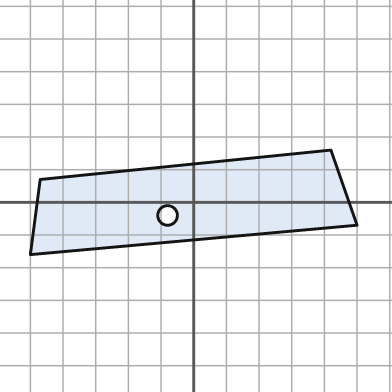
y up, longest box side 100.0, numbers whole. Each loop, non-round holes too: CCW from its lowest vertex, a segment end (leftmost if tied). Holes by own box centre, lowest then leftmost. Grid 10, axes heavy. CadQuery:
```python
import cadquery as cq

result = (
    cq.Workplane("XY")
    .moveTo(-50.0, -16.0)
    .lineTo(50.0, -7.0)
    .lineTo(42.0, 16.0)
    .lineTo(-47.0, 7.0)
    .close()
    .moveTo(-8.0, -4.0)
    .circle(3.0)
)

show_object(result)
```